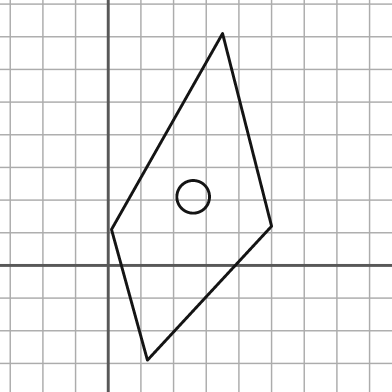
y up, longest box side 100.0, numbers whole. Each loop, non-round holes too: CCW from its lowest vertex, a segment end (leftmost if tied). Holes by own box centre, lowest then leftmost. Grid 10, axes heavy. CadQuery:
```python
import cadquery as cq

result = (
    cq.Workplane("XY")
    .moveTo(12.0, -29.0)
    .lineTo(50.0, 12.0)
    .lineTo(35.0, 71.0)
    .lineTo(1.0, 11.0)
    .close()
    .moveTo(26.0, 21.0)
    .circle(5.0)
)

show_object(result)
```